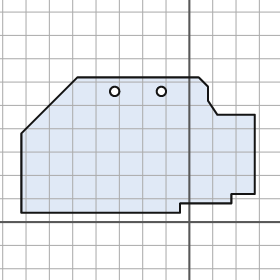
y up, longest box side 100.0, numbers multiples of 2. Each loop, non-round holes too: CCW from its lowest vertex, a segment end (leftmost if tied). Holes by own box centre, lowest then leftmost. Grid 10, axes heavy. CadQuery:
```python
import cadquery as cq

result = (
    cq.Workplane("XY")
    .moveTo(-72.0, 4.0)
    .lineTo(-4.0, 4.0)
    .lineTo(-4.0, 8.0)
    .lineTo(18.0, 8.0)
    .lineTo(18.0, 12.0)
    .lineTo(28.0, 12.0)
    .lineTo(28.0, 46.0)
    .lineTo(12.0, 46.0)
    .lineTo(8.0, 52.0)
    .lineTo(8.0, 58.0)
    .lineTo(4.0, 62.0)
    .lineTo(-48.0, 62.0)
    .lineTo(-72.0, 38.0)
    .close()
    .moveTo(-32.0, 56.0)
    .circle(2.0)
    .moveTo(-12.0, 56.0)
    .circle(2.0)
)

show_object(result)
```